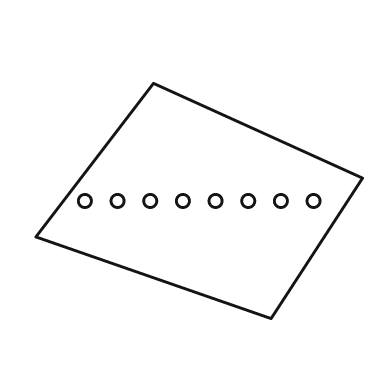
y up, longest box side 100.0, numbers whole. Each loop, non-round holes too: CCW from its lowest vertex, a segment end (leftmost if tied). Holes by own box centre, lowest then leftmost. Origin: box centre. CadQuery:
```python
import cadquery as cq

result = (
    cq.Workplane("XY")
    .moveTo(22.0, -36.0)
    .lineTo(50.0, 7.0)
    .lineTo(-14.0, 36.0)
    .lineTo(-50.0, -11.0)
    .close()
    .moveTo(-35.0, 0.0)
    .circle(2.0)
    .moveTo(-25.0, 0.0)
    .circle(2.0)
    .moveTo(-15.0, 0.0)
    .circle(2.0)
    .moveTo(-5.0, 0.0)
    .circle(2.0)
    .moveTo(5.0, 0.0)
    .circle(2.0)
    .moveTo(15.0, 0.0)
    .circle(2.0)
    .moveTo(25.0, 0.0)
    .circle(2.0)
    .moveTo(35.0, 0.0)
    .circle(2.0)
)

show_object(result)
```